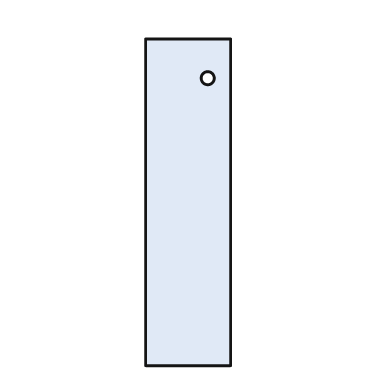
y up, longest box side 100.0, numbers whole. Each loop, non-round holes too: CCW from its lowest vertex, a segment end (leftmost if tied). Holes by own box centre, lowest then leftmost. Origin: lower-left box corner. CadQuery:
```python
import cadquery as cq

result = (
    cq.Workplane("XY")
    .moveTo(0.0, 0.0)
    .lineTo(26.0, 0.0)
    .lineTo(26.0, 100.0)
    .lineTo(0.0, 100.0)
    .close()
    .moveTo(19.0, 88.0)
    .circle(2.0)
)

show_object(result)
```